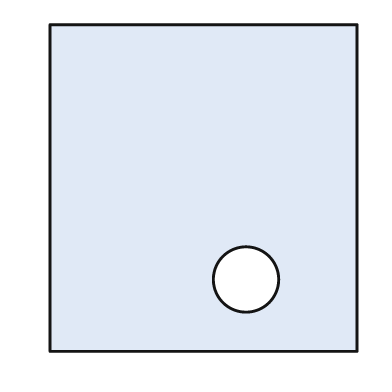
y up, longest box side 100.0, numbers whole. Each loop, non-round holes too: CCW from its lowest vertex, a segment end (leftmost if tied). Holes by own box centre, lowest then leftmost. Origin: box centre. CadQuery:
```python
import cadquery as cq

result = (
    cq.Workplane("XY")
    .moveTo(-47.0, -50.0)
    .lineTo(47.0, -50.0)
    .lineTo(47.0, 50.0)
    .lineTo(-47.0, 50.0)
    .close()
    .moveTo(13.0, -28.0)
    .circle(10.0)
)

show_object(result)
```